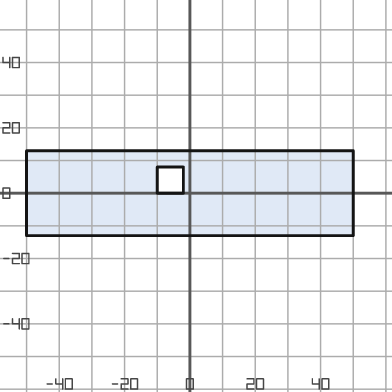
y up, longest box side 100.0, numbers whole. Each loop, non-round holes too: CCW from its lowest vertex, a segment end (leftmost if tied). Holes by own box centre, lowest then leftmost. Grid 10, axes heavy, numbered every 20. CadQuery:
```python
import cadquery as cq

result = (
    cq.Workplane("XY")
    .moveTo(-50.0, -13.0)
    .lineTo(50.0, -13.0)
    .lineTo(50.0, 13.0)
    .lineTo(-50.0, 13.0)
    .close()
    .moveTo(-10.0, 0.0)
    .lineTo(-2.0, 0.0)
    .lineTo(-2.0, 8.0)
    .lineTo(-10.0, 8.0)
    .close()
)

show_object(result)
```